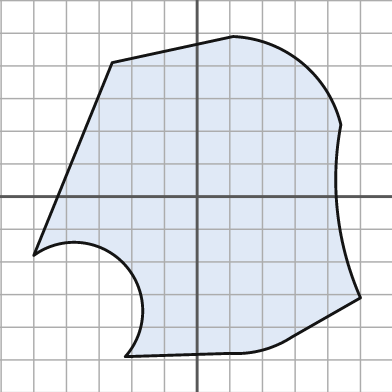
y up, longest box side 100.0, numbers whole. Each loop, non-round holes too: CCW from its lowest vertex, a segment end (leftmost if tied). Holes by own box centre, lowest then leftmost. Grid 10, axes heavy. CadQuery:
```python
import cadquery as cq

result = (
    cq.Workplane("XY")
    .moveTo(-22.0, -49.0)
    .lineTo(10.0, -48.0)
    .threePointArc((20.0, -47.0), (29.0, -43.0))
    .lineTo(50.0, -31.0)
    .threePointArc((43.0, -5.0), (44.0, 22.0))
    .threePointArc((32.0, 41.0), (11.0, 49.0))
    .lineTo(-26.0, 41.0)
    .lineTo(-50.0, -18.0)
    .threePointArc((-22.0, -21.0), (-22.0, -49.0))
    .close()
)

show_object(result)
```